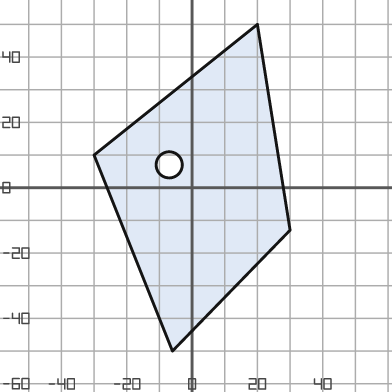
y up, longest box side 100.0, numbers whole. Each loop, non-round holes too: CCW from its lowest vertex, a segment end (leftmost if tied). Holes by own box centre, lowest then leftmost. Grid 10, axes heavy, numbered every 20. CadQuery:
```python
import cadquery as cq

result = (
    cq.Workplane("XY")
    .moveTo(-6.0, -50.0)
    .lineTo(30.0, -13.0)
    .lineTo(20.0, 50.0)
    .lineTo(-30.0, 10.0)
    .close()
    .moveTo(-7.0, 7.0)
    .circle(4.0)
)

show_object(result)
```